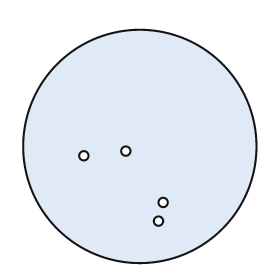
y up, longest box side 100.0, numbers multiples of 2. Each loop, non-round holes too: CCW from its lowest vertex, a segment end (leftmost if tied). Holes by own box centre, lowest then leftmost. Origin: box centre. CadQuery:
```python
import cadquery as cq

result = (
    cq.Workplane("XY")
    .moveTo(0.0, 0.0)
    .circle(50.0)
    .moveTo(8.0, -32.0)
    .circle(2.0)
    .moveTo(10.0, -24.0)
    .circle(2.0)
    .moveTo(-24.0, -4.0)
    .circle(2.0)
    .moveTo(-6.0, -2.0)
    .circle(2.0)
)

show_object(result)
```